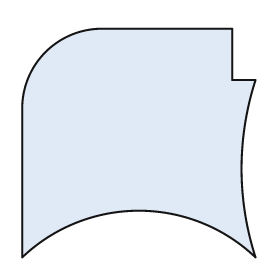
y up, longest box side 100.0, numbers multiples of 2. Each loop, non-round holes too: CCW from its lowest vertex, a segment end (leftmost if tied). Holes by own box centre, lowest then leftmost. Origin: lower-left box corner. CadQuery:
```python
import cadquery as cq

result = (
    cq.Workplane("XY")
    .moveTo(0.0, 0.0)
    .threePointArc((50.0, 20.0), (100.0, 0.0))
    .threePointArc((94.0, 38.0), (100.0, 76.0))
    .lineTo(90.0, 76.0)
    .lineTo(90.0, 98.0)
    .lineTo(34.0, 98.0)
    .threePointArc((10.0, 88.0), (0.0, 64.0))
    .close()
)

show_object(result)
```